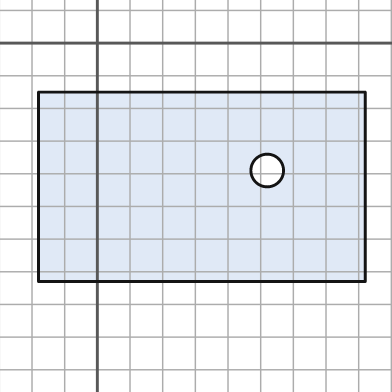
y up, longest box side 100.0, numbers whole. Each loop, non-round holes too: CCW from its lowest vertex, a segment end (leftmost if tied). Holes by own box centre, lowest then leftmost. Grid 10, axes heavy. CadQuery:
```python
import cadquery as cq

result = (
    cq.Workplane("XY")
    .moveTo(-18.0, -73.0)
    .lineTo(82.0, -73.0)
    .lineTo(82.0, -15.0)
    .lineTo(-18.0, -15.0)
    .close()
    .moveTo(52.0, -39.0)
    .circle(5.0)
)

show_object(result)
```